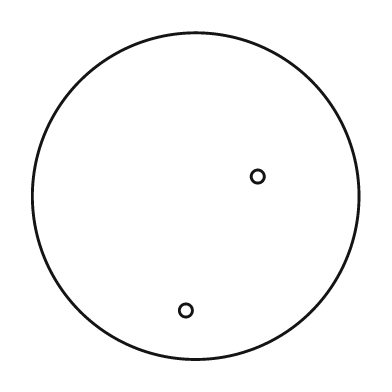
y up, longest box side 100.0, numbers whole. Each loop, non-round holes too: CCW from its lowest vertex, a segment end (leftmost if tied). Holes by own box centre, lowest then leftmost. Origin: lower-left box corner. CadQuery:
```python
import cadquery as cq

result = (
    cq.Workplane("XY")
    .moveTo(50.0, 50.0)
    .circle(50.0)
    .moveTo(47.0, 15.0)
    .circle(2.0)
    .moveTo(69.0, 56.0)
    .circle(2.0)
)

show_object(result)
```